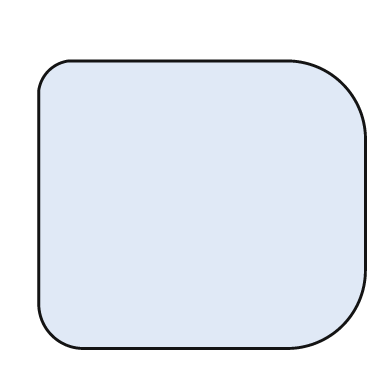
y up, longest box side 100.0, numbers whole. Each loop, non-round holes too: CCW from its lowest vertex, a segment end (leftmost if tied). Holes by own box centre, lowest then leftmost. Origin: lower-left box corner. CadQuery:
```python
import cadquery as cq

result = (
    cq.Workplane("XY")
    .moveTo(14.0, 0.0)
    .lineTo(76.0, 0.0)
    .threePointArc((93.0, 7.0), (100.0, 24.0))
    .lineTo(100.0, 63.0)
    .threePointArc((93.0, 81.0), (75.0, 88.0))
    .lineTo(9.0, 88.0)
    .threePointArc((3.0, 85.0), (0.0, 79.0))
    .lineTo(0.0, 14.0)
    .threePointArc((4.0, 4.0), (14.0, 0.0))
    .close()
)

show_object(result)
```